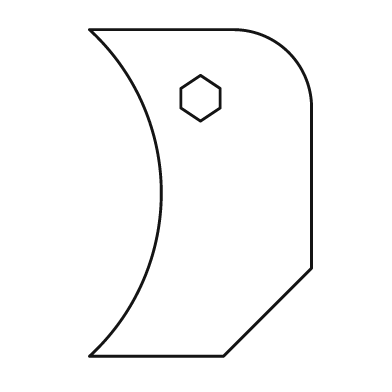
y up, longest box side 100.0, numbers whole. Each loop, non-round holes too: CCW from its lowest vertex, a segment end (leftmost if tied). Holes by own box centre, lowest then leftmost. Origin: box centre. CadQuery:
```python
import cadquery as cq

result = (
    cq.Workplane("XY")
    .moveTo(-34.0, -50.0)
    .lineTo(7.0, -50.0)
    .lineTo(34.0, -23.0)
    .lineTo(34.0, 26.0)
    .threePointArc((27.0, 43.0), (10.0, 50.0))
    .lineTo(-34.0, 50.0)
    .threePointArc((-12.0, 0.0), (-34.0, -50.0))
    .close()
    .moveTo(0.0, 22.0)
    .lineTo(6.0, 26.0)
    .lineTo(6.0, 32.0)
    .lineTo(0.0, 36.0)
    .lineTo(-6.0, 32.0)
    .lineTo(-6.0, 26.0)
    .close()
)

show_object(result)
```